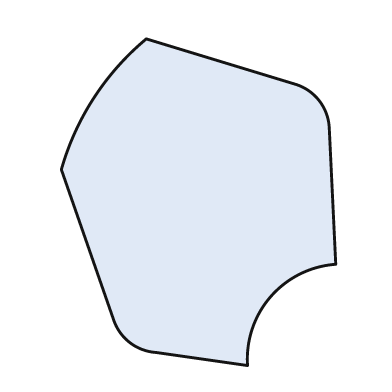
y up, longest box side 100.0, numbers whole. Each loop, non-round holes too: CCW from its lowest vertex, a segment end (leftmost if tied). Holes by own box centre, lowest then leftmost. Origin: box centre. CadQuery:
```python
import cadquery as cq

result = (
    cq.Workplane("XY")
    .moveTo(15.0, -50.0)
    .threePointArc((22.0, -29.0), (42.0, -19.0))
    .lineTo(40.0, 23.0)
    .threePointArc((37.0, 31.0), (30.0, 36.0))
    .lineTo(-16.0, 50.0)
    .threePointArc((-32.0, 32.0), (-42.0, 10.0))
    .lineTo(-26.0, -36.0)
    .threePointArc((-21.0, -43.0), (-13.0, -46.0))
    .close()
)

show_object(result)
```